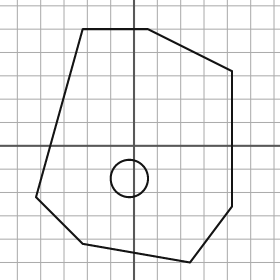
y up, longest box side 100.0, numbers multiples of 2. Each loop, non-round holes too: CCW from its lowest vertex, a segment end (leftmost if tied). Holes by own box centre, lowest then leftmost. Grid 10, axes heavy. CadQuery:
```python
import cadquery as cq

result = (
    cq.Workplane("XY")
    .moveTo(24.0, -50.0)
    .lineTo(42.0, -26.0)
    .lineTo(42.0, 32.0)
    .lineTo(6.0, 50.0)
    .lineTo(-22.0, 50.0)
    .lineTo(-42.0, -22.0)
    .lineTo(-22.0, -42.0)
    .close()
    .moveTo(-2.0, -14.0)
    .circle(8.0)
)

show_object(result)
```